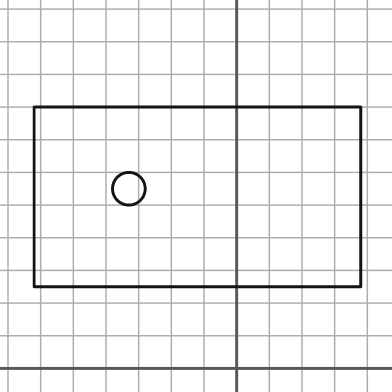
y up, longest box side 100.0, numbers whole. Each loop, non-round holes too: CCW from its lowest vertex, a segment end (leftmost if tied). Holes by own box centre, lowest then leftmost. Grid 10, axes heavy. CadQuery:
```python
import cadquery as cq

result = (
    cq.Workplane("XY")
    .moveTo(-62.0, 25.0)
    .lineTo(38.0, 25.0)
    .lineTo(38.0, 80.0)
    .lineTo(-62.0, 80.0)
    .close()
    .moveTo(-33.0, 55.0)
    .circle(5.0)
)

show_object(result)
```